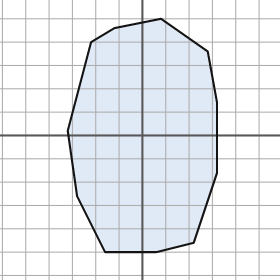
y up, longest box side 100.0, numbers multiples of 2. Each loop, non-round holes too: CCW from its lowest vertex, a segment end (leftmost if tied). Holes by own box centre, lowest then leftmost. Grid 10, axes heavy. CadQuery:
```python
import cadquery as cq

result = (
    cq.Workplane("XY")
    .moveTo(-16.0, -50.0)
    .lineTo(6.0, -50.0)
    .lineTo(22.0, -46.0)
    .lineTo(32.0, -16.0)
    .lineTo(32.0, 14.0)
    .lineTo(28.0, 36.0)
    .lineTo(8.0, 50.0)
    .lineTo(-12.0, 46.0)
    .lineTo(-22.0, 40.0)
    .lineTo(-32.0, 2.0)
    .lineTo(-28.0, -26.0)
    .close()
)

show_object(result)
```